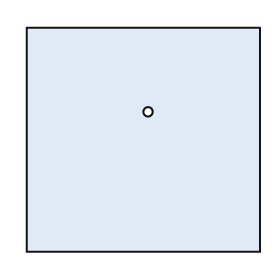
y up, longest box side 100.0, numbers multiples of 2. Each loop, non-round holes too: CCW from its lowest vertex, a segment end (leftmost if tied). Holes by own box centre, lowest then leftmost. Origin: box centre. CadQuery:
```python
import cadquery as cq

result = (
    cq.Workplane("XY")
    .moveTo(-50.0, -48.0)
    .lineTo(50.0, -48.0)
    .lineTo(50.0, 48.0)
    .lineTo(-50.0, 48.0)
    .close()
    .moveTo(2.0, 12.0)
    .circle(2.0)
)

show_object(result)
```